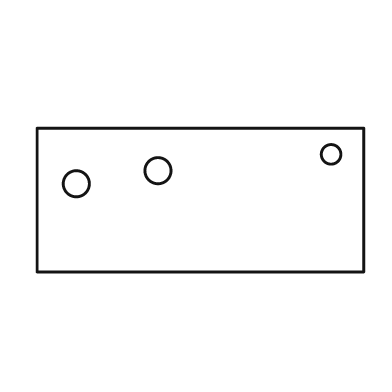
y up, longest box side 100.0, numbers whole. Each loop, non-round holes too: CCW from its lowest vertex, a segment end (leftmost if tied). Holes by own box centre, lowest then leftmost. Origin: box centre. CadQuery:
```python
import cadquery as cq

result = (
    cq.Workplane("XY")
    .moveTo(-50.0, -22.0)
    .lineTo(50.0, -22.0)
    .lineTo(50.0, 22.0)
    .lineTo(-50.0, 22.0)
    .close()
    .moveTo(-38.0, 5.0)
    .circle(4.0)
    .moveTo(-13.0, 9.0)
    .circle(4.0)
    .moveTo(40.0, 14.0)
    .circle(3.0)
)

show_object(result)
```